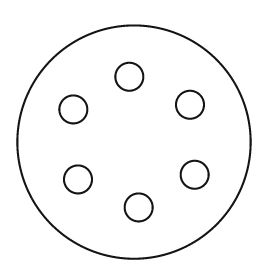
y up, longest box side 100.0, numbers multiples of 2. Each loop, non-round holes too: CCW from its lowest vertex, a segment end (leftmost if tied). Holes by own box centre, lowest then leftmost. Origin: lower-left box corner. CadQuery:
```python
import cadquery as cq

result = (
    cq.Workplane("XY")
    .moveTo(50.0, 50.0)
    .circle(50.0)
    .moveTo(52.0, 22.0)
    .circle(6.0)
    .moveTo(26.0, 34.0)
    .circle(6.0)
    .moveTo(76.0, 36.0)
    .circle(6.0)
    .moveTo(24.0, 64.0)
    .circle(6.0)
    .moveTo(74.0, 66.0)
    .circle(6.0)
    .moveTo(48.0, 78.0)
    .circle(6.0)
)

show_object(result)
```